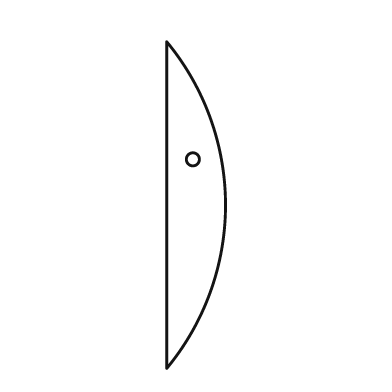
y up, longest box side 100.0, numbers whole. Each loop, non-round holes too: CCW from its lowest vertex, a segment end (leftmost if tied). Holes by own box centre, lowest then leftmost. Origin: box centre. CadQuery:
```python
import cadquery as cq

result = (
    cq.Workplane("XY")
    .moveTo(-9.0, -50.0)
    .threePointArc((9.0, 0.0), (-9.0, 50.0))
    .close()
    .moveTo(-1.0, 14.0)
    .circle(2.0)
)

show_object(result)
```